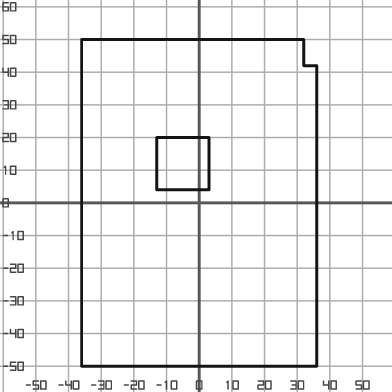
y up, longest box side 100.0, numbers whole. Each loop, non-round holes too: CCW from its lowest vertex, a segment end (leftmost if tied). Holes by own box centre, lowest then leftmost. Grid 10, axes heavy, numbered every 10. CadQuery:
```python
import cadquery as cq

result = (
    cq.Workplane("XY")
    .moveTo(-36.0, -50.0)
    .lineTo(36.0, -50.0)
    .lineTo(36.0, 42.0)
    .lineTo(32.0, 42.0)
    .lineTo(32.0, 50.0)
    .lineTo(-36.0, 50.0)
    .close()
    .moveTo(-13.0, 4.0)
    .lineTo(3.0, 4.0)
    .lineTo(3.0, 20.0)
    .lineTo(-13.0, 20.0)
    .close()
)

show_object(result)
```